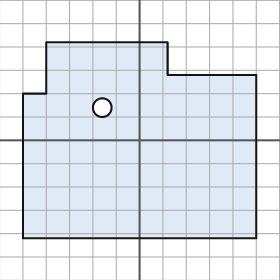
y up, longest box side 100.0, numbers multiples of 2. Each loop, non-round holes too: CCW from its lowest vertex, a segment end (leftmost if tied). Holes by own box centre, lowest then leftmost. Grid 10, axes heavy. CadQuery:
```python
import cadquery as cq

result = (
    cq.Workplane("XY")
    .moveTo(-50.0, -42.0)
    .lineTo(50.0, -42.0)
    .lineTo(50.0, 28.0)
    .lineTo(12.0, 28.0)
    .lineTo(12.0, 42.0)
    .lineTo(-40.0, 42.0)
    .lineTo(-40.0, 20.0)
    .lineTo(-50.0, 20.0)
    .close()
    .moveTo(-16.0, 14.0)
    .circle(4.0)
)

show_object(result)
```